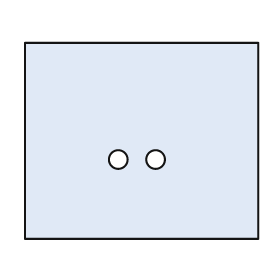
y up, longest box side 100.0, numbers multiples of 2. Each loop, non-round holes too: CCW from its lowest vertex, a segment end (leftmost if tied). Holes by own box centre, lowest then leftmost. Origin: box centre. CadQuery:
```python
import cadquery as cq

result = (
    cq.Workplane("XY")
    .moveTo(-50.0, -42.0)
    .lineTo(50.0, -42.0)
    .lineTo(50.0, 42.0)
    .lineTo(-50.0, 42.0)
    .close()
    .moveTo(-10.0, -8.0)
    .circle(4.0)
    .moveTo(6.0, -8.0)
    .circle(4.0)
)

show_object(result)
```